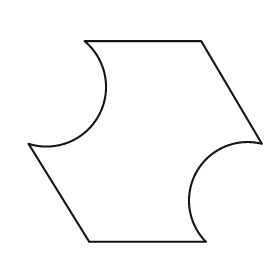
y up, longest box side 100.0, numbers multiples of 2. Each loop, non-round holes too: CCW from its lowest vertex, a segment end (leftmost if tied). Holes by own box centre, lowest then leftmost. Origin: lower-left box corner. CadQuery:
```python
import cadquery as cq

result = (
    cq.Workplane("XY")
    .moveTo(26.0, 0.0)
    .lineTo(76.0, 0.0)
    .threePointArc((72.0, 30.0), (100.0, 42.0))
    .lineTo(74.0, 86.0)
    .lineTo(24.0, 86.0)
    .threePointArc((30.0, 54.0), (0.0, 42.0))
    .close()
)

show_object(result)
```